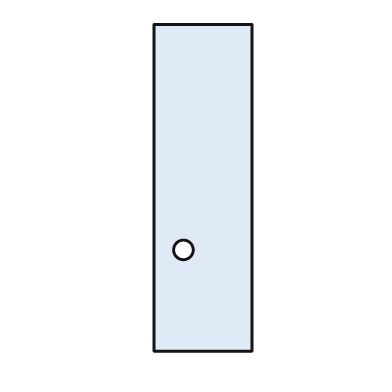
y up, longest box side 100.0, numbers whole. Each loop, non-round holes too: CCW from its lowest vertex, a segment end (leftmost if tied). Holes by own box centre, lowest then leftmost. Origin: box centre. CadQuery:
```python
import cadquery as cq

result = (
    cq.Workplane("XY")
    .moveTo(-15.0, -50.0)
    .lineTo(15.0, -50.0)
    .lineTo(15.0, 50.0)
    .lineTo(-15.0, 50.0)
    .close()
    .moveTo(-6.0, -19.0)
    .circle(3.0)
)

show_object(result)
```